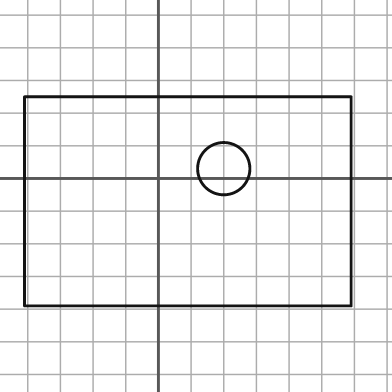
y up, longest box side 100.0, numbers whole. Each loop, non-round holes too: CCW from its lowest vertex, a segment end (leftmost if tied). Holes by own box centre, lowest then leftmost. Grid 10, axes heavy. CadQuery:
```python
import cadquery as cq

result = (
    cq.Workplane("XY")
    .moveTo(-41.0, -39.0)
    .lineTo(59.0, -39.0)
    .lineTo(59.0, 25.0)
    .lineTo(-41.0, 25.0)
    .close()
    .moveTo(20.0, 3.0)
    .circle(8.0)
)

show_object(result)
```